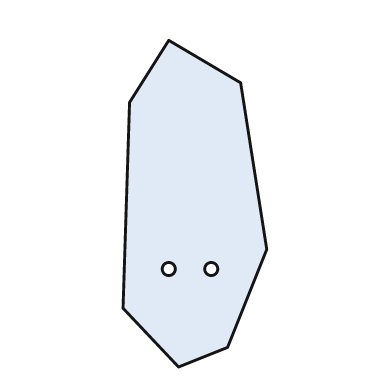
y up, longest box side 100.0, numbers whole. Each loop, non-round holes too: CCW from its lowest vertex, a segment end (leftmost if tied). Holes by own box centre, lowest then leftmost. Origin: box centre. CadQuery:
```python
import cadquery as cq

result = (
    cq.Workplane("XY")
    .moveTo(-5.0, -50.0)
    .lineTo(10.0, -44.0)
    .lineTo(22.0, -14.0)
    .lineTo(14.0, 37.0)
    .lineTo(-8.0, 50.0)
    .lineTo(-20.0, 31.0)
    .lineTo(-22.0, -32.0)
    .close()
    .moveTo(-8.0, -20.0)
    .circle(2.0)
    .moveTo(5.0, -20.0)
    .circle(2.0)
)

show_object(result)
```